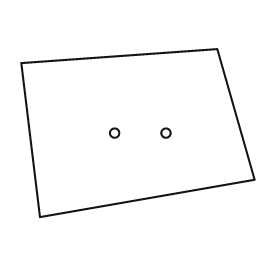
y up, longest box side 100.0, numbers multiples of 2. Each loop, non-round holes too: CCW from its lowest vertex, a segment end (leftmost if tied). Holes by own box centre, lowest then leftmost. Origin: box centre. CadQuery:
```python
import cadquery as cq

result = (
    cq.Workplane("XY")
    .moveTo(-42.0, -36.0)
    .lineTo(50.0, -20.0)
    .lineTo(34.0, 36.0)
    .lineTo(-50.0, 30.0)
    .close()
    .moveTo(-10.0, 0.0)
    .circle(2.0)
    .moveTo(12.0, 0.0)
    .circle(2.0)
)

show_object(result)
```